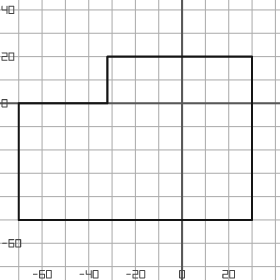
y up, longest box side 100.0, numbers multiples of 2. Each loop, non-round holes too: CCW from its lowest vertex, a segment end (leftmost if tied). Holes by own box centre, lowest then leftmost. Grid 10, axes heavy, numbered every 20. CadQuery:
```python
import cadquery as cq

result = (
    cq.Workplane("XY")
    .moveTo(-70.0, -50.0)
    .lineTo(30.0, -50.0)
    .lineTo(30.0, 20.0)
    .lineTo(-32.0, 20.0)
    .lineTo(-32.0, 0.0)
    .lineTo(-70.0, 0.0)
    .close()
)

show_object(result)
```